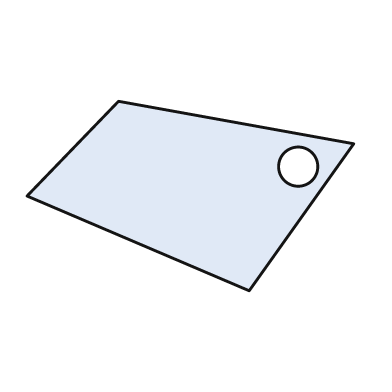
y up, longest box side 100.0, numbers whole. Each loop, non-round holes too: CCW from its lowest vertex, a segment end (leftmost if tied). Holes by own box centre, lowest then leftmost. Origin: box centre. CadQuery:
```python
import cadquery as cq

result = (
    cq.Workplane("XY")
    .moveTo(18.0, -29.0)
    .lineTo(50.0, 16.0)
    .lineTo(-22.0, 29.0)
    .lineTo(-50.0, 0.0)
    .close()
    .moveTo(33.0, 9.0)
    .circle(6.0)
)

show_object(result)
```